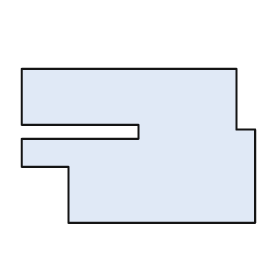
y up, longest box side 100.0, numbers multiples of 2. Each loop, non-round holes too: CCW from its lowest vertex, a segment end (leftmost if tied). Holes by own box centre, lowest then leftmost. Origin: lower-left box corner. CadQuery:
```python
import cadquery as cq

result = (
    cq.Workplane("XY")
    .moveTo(20.0, 0.0)
    .lineTo(100.0, 0.0)
    .lineTo(100.0, 40.0)
    .lineTo(92.0, 40.0)
    .lineTo(92.0, 66.0)
    .lineTo(0.0, 66.0)
    .lineTo(0.0, 42.0)
    .lineTo(50.0, 42.0)
    .lineTo(50.0, 36.0)
    .lineTo(0.0, 36.0)
    .lineTo(0.0, 24.0)
    .lineTo(20.0, 24.0)
    .close()
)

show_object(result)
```